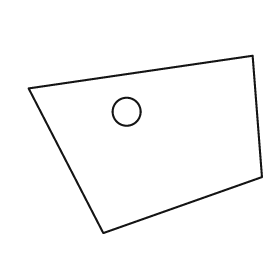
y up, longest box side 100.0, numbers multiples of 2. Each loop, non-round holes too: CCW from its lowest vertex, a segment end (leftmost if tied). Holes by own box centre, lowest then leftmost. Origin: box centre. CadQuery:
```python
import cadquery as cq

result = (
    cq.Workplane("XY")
    .moveTo(-18.0, -38.0)
    .lineTo(50.0, -14.0)
    .lineTo(46.0, 38.0)
    .lineTo(-50.0, 24.0)
    .close()
    .moveTo(-8.0, 14.0)
    .circle(6.0)
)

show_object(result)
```